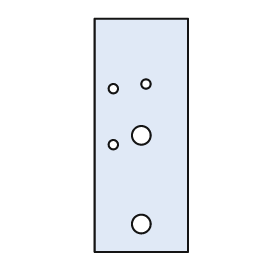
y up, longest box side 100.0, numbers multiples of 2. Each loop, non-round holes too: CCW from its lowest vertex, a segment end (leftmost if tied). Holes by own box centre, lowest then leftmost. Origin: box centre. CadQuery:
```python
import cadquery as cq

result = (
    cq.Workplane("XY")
    .moveTo(-20.0, -50.0)
    .lineTo(20.0, -50.0)
    .lineTo(20.0, 50.0)
    .lineTo(-20.0, 50.0)
    .close()
    .moveTo(0.0, -38.0)
    .circle(4.0)
    .moveTo(-12.0, -4.0)
    .circle(2.0)
    .moveTo(0.0, 0.0)
    .circle(4.0)
    .moveTo(-12.0, 20.0)
    .circle(2.0)
    .moveTo(2.0, 22.0)
    .circle(2.0)
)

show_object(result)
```